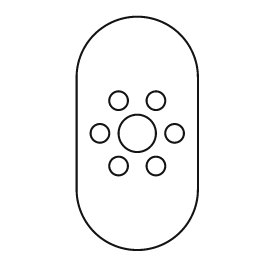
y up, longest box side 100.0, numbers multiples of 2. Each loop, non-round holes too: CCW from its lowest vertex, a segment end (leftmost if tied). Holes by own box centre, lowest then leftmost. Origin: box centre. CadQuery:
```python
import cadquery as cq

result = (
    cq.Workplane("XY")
    .moveTo(-26.0, -24.0)
    .threePointArc((0.0, -50.0), (26.0, -24.0))
    .lineTo(26.0, 24.0)
    .threePointArc((0.0, 50.0), (-26.0, 24.0))
    .close()
    .moveTo(-8.0, -14.0)
    .circle(4.0)
    .moveTo(8.0, -14.0)
    .circle(4.0)
    .moveTo(-16.0, 0.0)
    .circle(4.0)
    .moveTo(0.0, 0.0)
    .circle(8.0)
    .moveTo(16.0, 0.0)
    .circle(4.0)
    .moveTo(-8.0, 14.0)
    .circle(4.0)
    .moveTo(8.0, 14.0)
    .circle(4.0)
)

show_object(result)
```